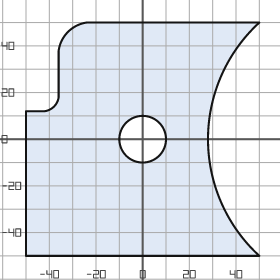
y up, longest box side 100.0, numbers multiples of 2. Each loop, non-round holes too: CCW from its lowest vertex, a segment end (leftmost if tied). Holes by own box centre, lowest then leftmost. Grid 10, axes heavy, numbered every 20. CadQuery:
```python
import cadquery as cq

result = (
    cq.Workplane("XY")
    .moveTo(-50.0, -50.0)
    .lineTo(50.0, -50.0)
    .threePointArc((28.0, 0.0), (50.0, 50.0))
    .lineTo(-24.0, 50.0)
    .threePointArc((-32.0, 46.0), (-36.0, 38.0))
    .lineTo(-36.0, 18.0)
    .threePointArc((-38.0, 14.0), (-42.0, 12.0))
    .lineTo(-50.0, 12.0)
    .close()
    .moveTo(0.0, 0.0)
    .circle(10.0)
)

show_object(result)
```